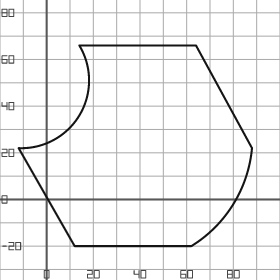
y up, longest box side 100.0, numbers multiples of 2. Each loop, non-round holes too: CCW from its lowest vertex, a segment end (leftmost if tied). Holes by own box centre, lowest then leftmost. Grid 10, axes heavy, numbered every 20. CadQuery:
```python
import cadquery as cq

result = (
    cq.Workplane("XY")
    .moveTo(12.0, -20.0)
    .lineTo(62.0, -20.0)
    .threePointArc((80.0, -2.0), (88.0, 22.0))
    .lineTo(64.0, 66.0)
    .lineTo(14.0, 66.0)
    .threePointArc((14.0, 36.0), (-12.0, 22.0))
    .close()
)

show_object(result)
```